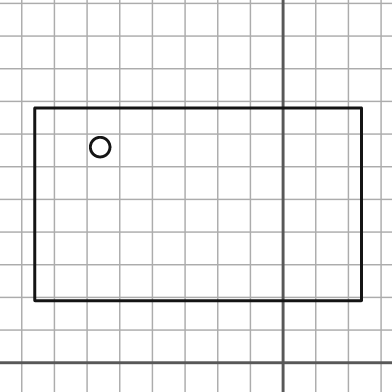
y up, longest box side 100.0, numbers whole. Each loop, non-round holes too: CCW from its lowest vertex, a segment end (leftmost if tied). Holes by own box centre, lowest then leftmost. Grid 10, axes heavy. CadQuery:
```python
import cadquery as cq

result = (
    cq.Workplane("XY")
    .moveTo(-76.0, 19.0)
    .lineTo(24.0, 19.0)
    .lineTo(24.0, 78.0)
    .lineTo(-76.0, 78.0)
    .close()
    .moveTo(-56.0, 66.0)
    .circle(3.0)
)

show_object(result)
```